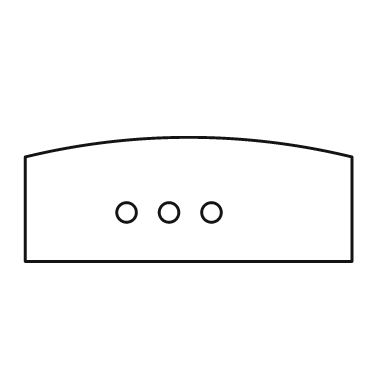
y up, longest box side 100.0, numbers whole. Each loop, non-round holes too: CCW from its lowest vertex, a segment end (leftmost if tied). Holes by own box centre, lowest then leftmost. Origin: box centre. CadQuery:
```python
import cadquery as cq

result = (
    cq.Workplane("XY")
    .moveTo(-50.0, -19.0)
    .lineTo(50.0, -19.0)
    .lineTo(50.0, 13.0)
    .threePointArc((0.0, 19.0), (-50.0, 13.0))
    .close()
    .moveTo(-19.0, -4.0)
    .circle(3.0)
    .moveTo(-6.0, -4.0)
    .circle(3.0)
    .moveTo(7.0, -4.0)
    .circle(3.0)
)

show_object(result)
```